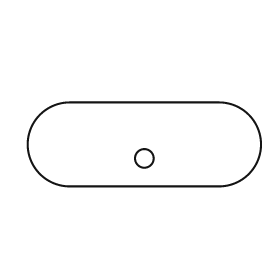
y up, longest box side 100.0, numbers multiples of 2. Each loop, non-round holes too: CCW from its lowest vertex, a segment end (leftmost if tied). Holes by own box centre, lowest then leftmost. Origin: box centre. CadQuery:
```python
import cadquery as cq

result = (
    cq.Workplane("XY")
    .moveTo(-32.0, -18.0)
    .lineTo(32.0, -18.0)
    .threePointArc((50.0, 0.0), (32.0, 18.0))
    .lineTo(-32.0, 18.0)
    .threePointArc((-50.0, 0.0), (-32.0, -18.0))
    .close()
    .moveTo(0.0, -6.0)
    .circle(4.0)
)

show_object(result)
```